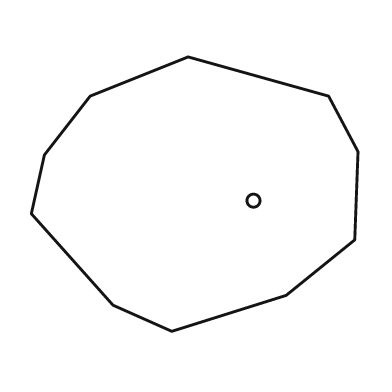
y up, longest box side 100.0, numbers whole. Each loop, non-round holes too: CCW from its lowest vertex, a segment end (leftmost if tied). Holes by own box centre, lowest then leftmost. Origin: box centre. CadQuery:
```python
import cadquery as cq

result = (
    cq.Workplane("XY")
    .moveTo(-7.0, -42.0)
    .lineTo(28.0, -31.0)
    .lineTo(49.0, -14.0)
    .lineTo(50.0, 13.0)
    .lineTo(41.0, 30.0)
    .lineTo(-2.0, 42.0)
    .lineTo(-32.0, 30.0)
    .lineTo(-46.0, 12.0)
    .lineTo(-50.0, -6.0)
    .lineTo(-25.0, -34.0)
    .close()
    .moveTo(18.0, -2.0)
    .circle(2.0)
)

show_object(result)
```